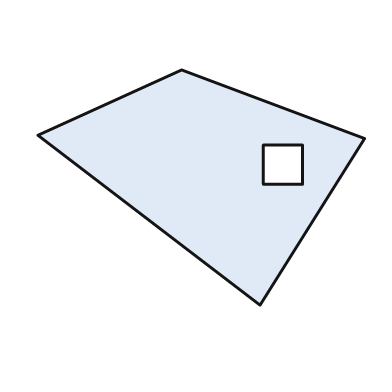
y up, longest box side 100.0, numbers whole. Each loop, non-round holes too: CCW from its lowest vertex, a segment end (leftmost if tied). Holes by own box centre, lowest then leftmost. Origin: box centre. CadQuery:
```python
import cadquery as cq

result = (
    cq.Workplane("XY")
    .moveTo(18.0, -36.0)
    .lineTo(50.0, 15.0)
    .lineTo(-6.0, 36.0)
    .lineTo(-50.0, 16.0)
    .close()
    .moveTo(19.0, 1.0)
    .lineTo(31.0, 1.0)
    .lineTo(31.0, 13.0)
    .lineTo(19.0, 13.0)
    .close()
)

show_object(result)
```